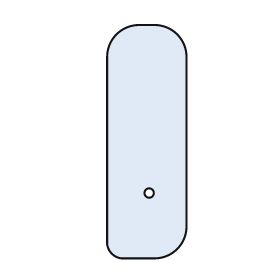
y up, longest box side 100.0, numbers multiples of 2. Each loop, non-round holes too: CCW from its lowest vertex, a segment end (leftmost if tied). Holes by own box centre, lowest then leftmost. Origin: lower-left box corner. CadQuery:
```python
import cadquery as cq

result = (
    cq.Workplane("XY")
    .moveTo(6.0, 0.0)
    .lineTo(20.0, 0.0)
    .threePointArc((30.0, 4.0), (34.0, 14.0))
    .lineTo(34.0, 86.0)
    .threePointArc((30.0, 96.0), (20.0, 100.0))
    .lineTo(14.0, 100.0)
    .threePointArc((4.0, 96.0), (0.0, 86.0))
    .lineTo(0.0, 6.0)
    .threePointArc((2.0, 2.0), (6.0, 0.0))
    .close()
    .moveTo(18.0, 28.0)
    .circle(2.0)
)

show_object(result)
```